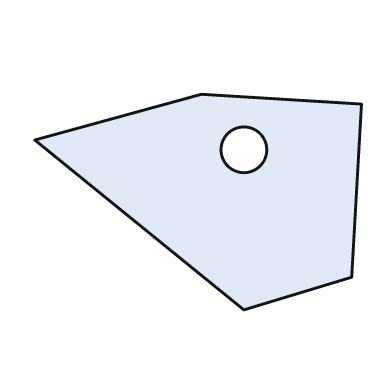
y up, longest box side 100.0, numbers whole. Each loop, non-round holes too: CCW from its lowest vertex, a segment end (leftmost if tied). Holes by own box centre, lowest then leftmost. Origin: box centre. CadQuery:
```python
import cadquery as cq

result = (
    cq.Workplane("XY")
    .moveTo(14.0, -33.0)
    .lineTo(47.0, -23.0)
    .lineTo(50.0, 30.0)
    .lineTo(1.0, 33.0)
    .lineTo(-50.0, 19.0)
    .close()
    .moveTo(14.0, 16.0)
    .circle(7.0)
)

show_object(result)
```